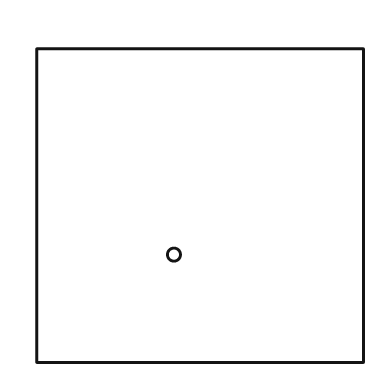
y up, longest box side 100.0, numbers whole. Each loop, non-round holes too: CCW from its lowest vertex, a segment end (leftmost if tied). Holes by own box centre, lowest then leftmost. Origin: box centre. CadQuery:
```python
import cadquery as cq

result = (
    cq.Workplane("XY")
    .moveTo(-50.0, -48.0)
    .lineTo(50.0, -48.0)
    .lineTo(50.0, 48.0)
    .lineTo(-50.0, 48.0)
    .close()
    .moveTo(-8.0, -15.0)
    .circle(2.0)
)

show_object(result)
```